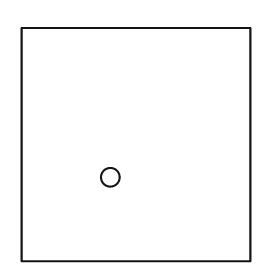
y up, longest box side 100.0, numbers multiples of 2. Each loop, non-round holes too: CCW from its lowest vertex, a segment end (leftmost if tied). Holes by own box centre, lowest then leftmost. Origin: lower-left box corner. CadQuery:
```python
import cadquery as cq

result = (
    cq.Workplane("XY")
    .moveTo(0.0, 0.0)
    .lineTo(98.0, 0.0)
    .lineTo(98.0, 100.0)
    .lineTo(0.0, 100.0)
    .close()
    .moveTo(38.0, 36.0)
    .circle(4.0)
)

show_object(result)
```